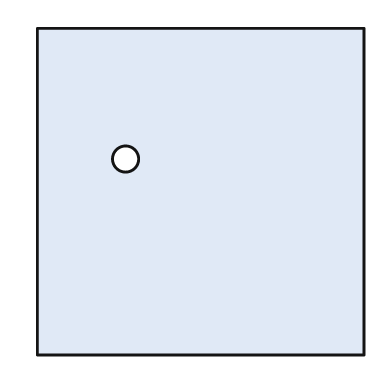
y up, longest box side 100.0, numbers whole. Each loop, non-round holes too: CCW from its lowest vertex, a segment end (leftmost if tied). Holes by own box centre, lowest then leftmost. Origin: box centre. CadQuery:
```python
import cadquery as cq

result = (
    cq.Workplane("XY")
    .moveTo(-50.0, -50.0)
    .lineTo(50.0, -50.0)
    .lineTo(50.0, 50.0)
    .lineTo(-50.0, 50.0)
    .close()
    .moveTo(-23.0, 10.0)
    .circle(4.0)
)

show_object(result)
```